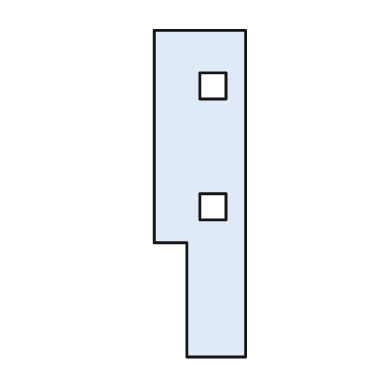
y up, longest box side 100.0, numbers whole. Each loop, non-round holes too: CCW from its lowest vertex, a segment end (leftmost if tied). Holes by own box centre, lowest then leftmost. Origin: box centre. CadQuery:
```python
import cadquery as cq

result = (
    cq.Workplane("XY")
    .moveTo(-4.0, -50.0)
    .lineTo(14.0, -50.0)
    .lineTo(14.0, 50.0)
    .lineTo(-14.0, 50.0)
    .lineTo(-14.0, -15.0)
    .lineTo(-4.0, -15.0)
    .close()
    .moveTo(0.0, -8.0)
    .lineTo(8.0, -8.0)
    .lineTo(8.0, 0.0)
    .lineTo(0.0, 0.0)
    .close()
    .moveTo(0.0, 29.0)
    .lineTo(8.0, 29.0)
    .lineTo(8.0, 37.0)
    .lineTo(0.0, 37.0)
    .close()
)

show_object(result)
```